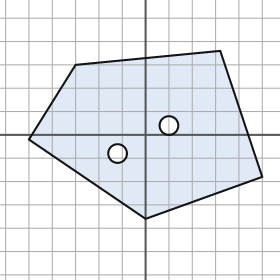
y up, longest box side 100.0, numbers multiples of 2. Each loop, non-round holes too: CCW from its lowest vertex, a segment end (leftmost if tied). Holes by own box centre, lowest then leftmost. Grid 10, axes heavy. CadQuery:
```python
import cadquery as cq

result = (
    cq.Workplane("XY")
    .moveTo(0.0, -36.0)
    .lineTo(50.0, -18.0)
    .lineTo(32.0, 36.0)
    .lineTo(-30.0, 30.0)
    .lineTo(-50.0, -2.0)
    .close()
    .moveTo(-12.0, -8.0)
    .circle(4.0)
    .moveTo(10.0, 4.0)
    .circle(4.0)
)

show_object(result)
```